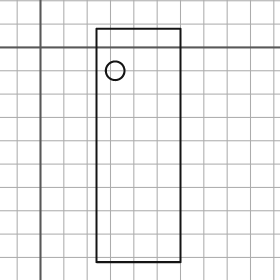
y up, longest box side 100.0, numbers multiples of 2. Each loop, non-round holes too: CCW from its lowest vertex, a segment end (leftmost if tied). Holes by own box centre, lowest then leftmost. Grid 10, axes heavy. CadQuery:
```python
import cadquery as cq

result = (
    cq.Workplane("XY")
    .moveTo(24.0, -92.0)
    .lineTo(60.0, -92.0)
    .lineTo(60.0, 8.0)
    .lineTo(24.0, 8.0)
    .close()
    .moveTo(32.0, -10.0)
    .circle(4.0)
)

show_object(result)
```